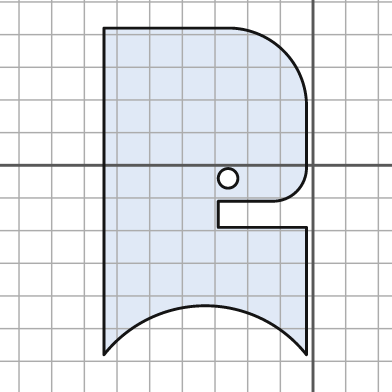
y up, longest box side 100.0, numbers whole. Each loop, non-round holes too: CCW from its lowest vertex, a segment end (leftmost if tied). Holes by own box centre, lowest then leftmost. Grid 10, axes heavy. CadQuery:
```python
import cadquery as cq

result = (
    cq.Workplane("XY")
    .moveTo(-64.0, -58.0)
    .threePointArc((-33.0, -43.0), (-2.0, -58.0))
    .lineTo(-2.0, -19.0)
    .lineTo(-29.0, -19.0)
    .lineTo(-29.0, -11.0)
    .lineTo(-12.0, -11.0)
    .threePointArc((-5.0, -8.0), (-2.0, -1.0))
    .lineTo(-2.0, 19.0)
    .threePointArc((-9.0, 35.0), (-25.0, 42.0))
    .lineTo(-64.0, 42.0)
    .close()
    .moveTo(-26.0, -4.0)
    .circle(3.0)
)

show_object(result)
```